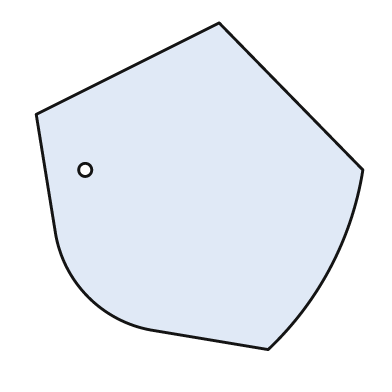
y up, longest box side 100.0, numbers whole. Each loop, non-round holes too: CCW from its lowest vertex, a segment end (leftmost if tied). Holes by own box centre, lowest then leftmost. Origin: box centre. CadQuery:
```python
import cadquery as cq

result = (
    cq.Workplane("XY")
    .moveTo(21.0, -50.0)
    .threePointArc((40.0, -25.0), (50.0, 5.0))
    .lineTo(6.0, 50.0)
    .lineTo(-50.0, 22.0)
    .lineTo(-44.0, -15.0)
    .threePointArc((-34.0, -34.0), (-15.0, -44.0))
    .close()
    .moveTo(-35.0, 5.0)
    .circle(2.0)
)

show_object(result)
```